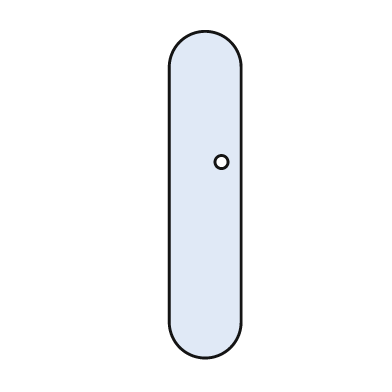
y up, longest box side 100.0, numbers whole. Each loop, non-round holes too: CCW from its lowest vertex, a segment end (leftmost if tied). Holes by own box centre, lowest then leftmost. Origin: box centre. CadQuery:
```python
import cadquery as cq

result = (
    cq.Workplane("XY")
    .moveTo(-11.0, -39.0)
    .threePointArc((0.0, -50.0), (11.0, -39.0))
    .lineTo(11.0, 39.0)
    .threePointArc((0.0, 50.0), (-11.0, 39.0))
    .close()
    .moveTo(5.0, 10.0)
    .circle(2.0)
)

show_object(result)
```